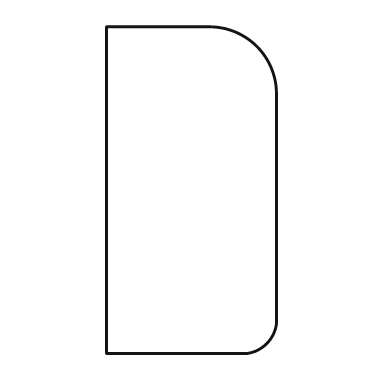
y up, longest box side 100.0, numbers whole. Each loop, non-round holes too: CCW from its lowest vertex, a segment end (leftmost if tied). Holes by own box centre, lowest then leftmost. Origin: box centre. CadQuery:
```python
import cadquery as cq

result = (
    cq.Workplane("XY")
    .moveTo(-26.0, -50.0)
    .lineTo(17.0, -50.0)
    .threePointArc((23.0, -47.0), (26.0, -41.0))
    .lineTo(26.0, 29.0)
    .threePointArc((20.0, 44.0), (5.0, 50.0))
    .lineTo(-26.0, 50.0)
    .close()
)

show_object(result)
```